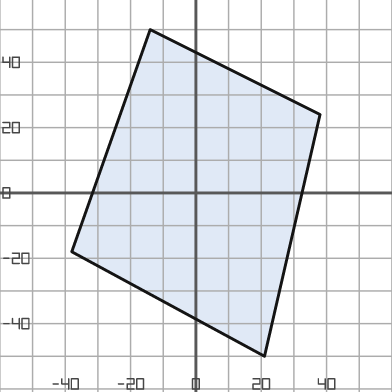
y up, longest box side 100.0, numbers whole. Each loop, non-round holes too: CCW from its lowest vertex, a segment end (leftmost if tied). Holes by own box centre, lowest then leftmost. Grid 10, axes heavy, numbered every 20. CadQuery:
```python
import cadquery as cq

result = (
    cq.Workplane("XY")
    .moveTo(21.0, -50.0)
    .lineTo(38.0, 24.0)
    .lineTo(-14.0, 50.0)
    .lineTo(-38.0, -18.0)
    .close()
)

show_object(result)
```